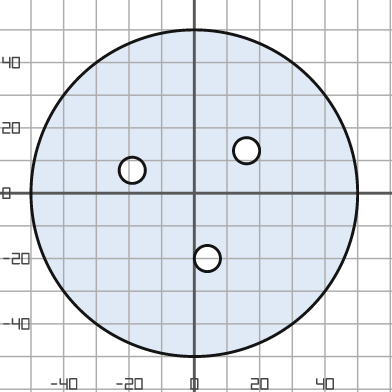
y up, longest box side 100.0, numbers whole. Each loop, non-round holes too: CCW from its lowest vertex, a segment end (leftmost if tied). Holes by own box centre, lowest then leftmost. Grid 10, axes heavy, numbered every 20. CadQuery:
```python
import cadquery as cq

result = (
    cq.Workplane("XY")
    .moveTo(0.0, 0.0)
    .circle(50.0)
    .moveTo(4.0, -20.0)
    .circle(4.0)
    .moveTo(-19.0, 7.0)
    .circle(4.0)
    .moveTo(16.0, 13.0)
    .circle(4.0)
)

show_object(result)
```